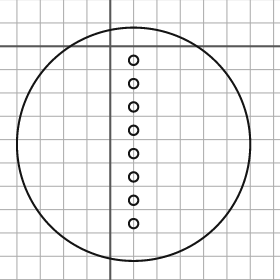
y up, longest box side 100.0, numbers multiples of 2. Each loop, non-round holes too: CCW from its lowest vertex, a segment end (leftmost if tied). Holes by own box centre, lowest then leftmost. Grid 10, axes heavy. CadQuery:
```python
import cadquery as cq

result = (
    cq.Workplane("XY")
    .moveTo(10.0, -42.0)
    .circle(50.0)
    .moveTo(10.0, -76.0)
    .circle(2.0)
    .moveTo(10.0, -66.0)
    .circle(2.0)
    .moveTo(10.0, -56.0)
    .circle(2.0)
    .moveTo(10.0, -46.0)
    .circle(2.0)
    .moveTo(10.0, -36.0)
    .circle(2.0)
    .moveTo(10.0, -26.0)
    .circle(2.0)
    .moveTo(10.0, -16.0)
    .circle(2.0)
    .moveTo(10.0, -6.0)
    .circle(2.0)
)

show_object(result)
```